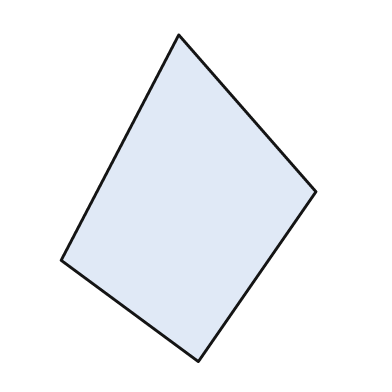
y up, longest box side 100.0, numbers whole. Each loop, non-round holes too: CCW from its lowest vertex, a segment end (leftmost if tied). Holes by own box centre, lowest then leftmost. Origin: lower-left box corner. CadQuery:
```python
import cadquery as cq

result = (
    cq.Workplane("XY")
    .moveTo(42.0, 0.0)
    .lineTo(78.0, 52.0)
    .lineTo(36.0, 100.0)
    .lineTo(0.0, 31.0)
    .close()
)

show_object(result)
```